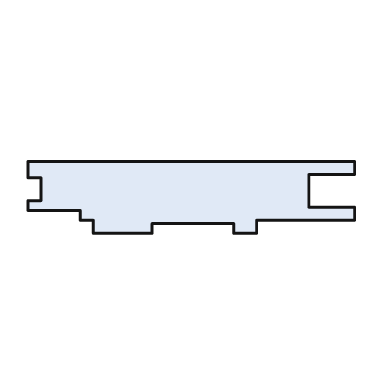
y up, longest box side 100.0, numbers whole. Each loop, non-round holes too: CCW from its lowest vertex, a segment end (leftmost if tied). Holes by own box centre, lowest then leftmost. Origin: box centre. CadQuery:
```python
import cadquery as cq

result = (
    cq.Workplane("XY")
    .moveTo(-30.0, -11.0)
    .lineTo(-12.0, -11.0)
    .lineTo(-12.0, -8.0)
    .lineTo(13.0, -8.0)
    .lineTo(13.0, -11.0)
    .lineTo(20.0, -11.0)
    .lineTo(20.0, -7.0)
    .lineTo(50.0, -7.0)
    .lineTo(50.0, -3.0)
    .lineTo(36.0, -3.0)
    .lineTo(36.0, 7.0)
    .lineTo(50.0, 7.0)
    .lineTo(50.0, 11.0)
    .lineTo(-50.0, 11.0)
    .lineTo(-50.0, 6.0)
    .lineTo(-46.0, 6.0)
    .lineTo(-46.0, -1.0)
    .lineTo(-50.0, -1.0)
    .lineTo(-50.0, -4.0)
    .lineTo(-34.0, -4.0)
    .lineTo(-34.0, -7.0)
    .lineTo(-30.0, -7.0)
    .close()
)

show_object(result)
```